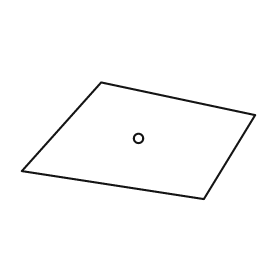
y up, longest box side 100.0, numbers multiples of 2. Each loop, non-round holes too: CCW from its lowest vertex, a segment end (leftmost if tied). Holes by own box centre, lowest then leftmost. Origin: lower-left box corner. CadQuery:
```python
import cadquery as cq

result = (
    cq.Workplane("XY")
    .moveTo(78.0, 0.0)
    .lineTo(100.0, 36.0)
    .lineTo(34.0, 50.0)
    .lineTo(0.0, 12.0)
    .close()
    .moveTo(50.0, 26.0)
    .circle(2.0)
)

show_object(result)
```